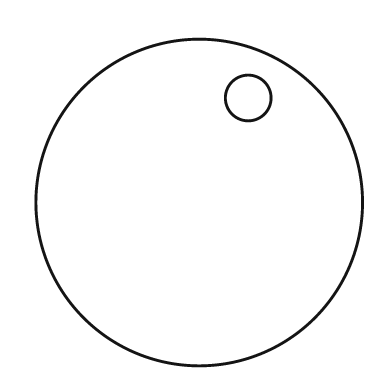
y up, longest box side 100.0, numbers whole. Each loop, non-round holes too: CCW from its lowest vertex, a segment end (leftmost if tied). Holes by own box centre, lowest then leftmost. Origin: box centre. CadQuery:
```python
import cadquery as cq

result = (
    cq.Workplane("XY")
    .moveTo(0.0, 0.0)
    .circle(50.0)
    .moveTo(15.0, 32.0)
    .circle(7.0)
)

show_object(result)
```